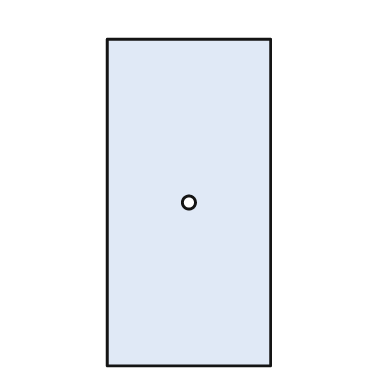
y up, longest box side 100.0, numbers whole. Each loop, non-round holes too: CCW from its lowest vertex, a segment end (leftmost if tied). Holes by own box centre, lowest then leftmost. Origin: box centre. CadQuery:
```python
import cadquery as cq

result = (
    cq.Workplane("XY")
    .moveTo(-25.0, -50.0)
    .lineTo(25.0, -50.0)
    .lineTo(25.0, 50.0)
    .lineTo(-25.0, 50.0)
    .close()
    .moveTo(0.0, 0.0)
    .circle(2.0)
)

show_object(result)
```